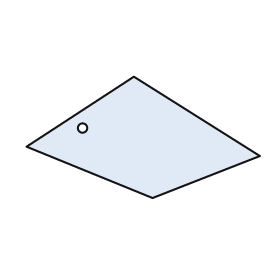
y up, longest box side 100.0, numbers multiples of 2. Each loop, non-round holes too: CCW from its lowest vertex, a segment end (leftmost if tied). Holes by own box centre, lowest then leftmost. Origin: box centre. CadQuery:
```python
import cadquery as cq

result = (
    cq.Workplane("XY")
    .moveTo(4.0, -26.0)
    .lineTo(50.0, -8.0)
    .lineTo(-4.0, 26.0)
    .lineTo(-50.0, -4.0)
    .close()
    .moveTo(-26.0, 4.0)
    .circle(2.0)
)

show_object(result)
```